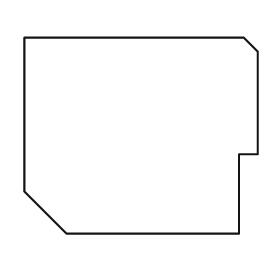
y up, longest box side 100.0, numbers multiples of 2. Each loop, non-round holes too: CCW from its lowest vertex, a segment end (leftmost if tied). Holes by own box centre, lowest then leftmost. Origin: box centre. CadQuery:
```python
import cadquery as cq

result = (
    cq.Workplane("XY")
    .moveTo(-32.0, -42.0)
    .lineTo(42.0, -42.0)
    .lineTo(42.0, -8.0)
    .lineTo(50.0, -8.0)
    .lineTo(50.0, 36.0)
    .lineTo(44.0, 42.0)
    .lineTo(-50.0, 42.0)
    .lineTo(-50.0, -24.0)
    .close()
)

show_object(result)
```